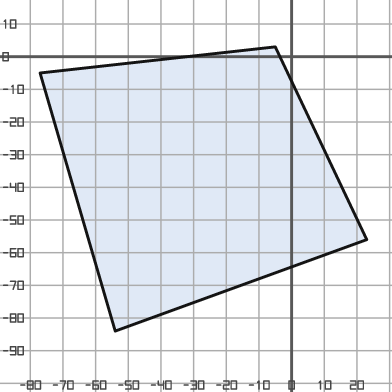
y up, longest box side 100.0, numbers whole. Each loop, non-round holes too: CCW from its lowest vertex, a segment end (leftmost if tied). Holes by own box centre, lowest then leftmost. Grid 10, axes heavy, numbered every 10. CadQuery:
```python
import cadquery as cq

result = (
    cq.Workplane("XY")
    .moveTo(-54.0, -84.0)
    .lineTo(23.0, -56.0)
    .lineTo(-5.0, 3.0)
    .lineTo(-77.0, -5.0)
    .close()
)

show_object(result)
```